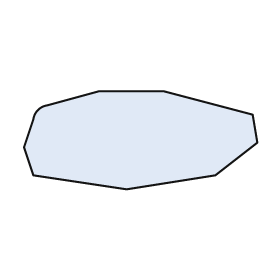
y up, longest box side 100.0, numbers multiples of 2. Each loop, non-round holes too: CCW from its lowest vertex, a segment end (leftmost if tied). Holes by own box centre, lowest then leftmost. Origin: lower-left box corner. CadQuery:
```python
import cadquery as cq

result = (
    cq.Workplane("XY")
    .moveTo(44.0, 0.0)
    .lineTo(82.0, 6.0)
    .lineTo(100.0, 20.0)
    .lineTo(98.0, 32.0)
    .lineTo(60.0, 42.0)
    .lineTo(32.0, 42.0)
    .lineTo(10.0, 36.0)
    .threePointArc((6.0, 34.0), (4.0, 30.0))
    .lineTo(0.0, 18.0)
    .lineTo(4.0, 6.0)
    .close()
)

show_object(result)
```